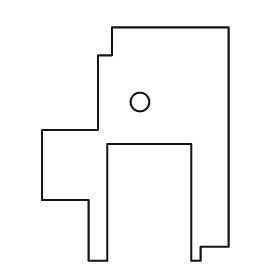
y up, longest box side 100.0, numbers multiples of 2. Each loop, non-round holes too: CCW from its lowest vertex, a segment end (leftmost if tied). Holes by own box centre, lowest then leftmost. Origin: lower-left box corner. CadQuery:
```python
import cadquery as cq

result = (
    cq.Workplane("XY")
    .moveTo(20.0, 0.0)
    .lineTo(28.0, 0.0)
    .lineTo(28.0, 50.0)
    .lineTo(64.0, 50.0)
    .lineTo(64.0, 0.0)
    .lineTo(68.0, 0.0)
    .lineTo(68.0, 6.0)
    .lineTo(80.0, 6.0)
    .lineTo(80.0, 100.0)
    .lineTo(30.0, 100.0)
    .lineTo(30.0, 88.0)
    .lineTo(24.0, 88.0)
    .lineTo(24.0, 56.0)
    .lineTo(0.0, 56.0)
    .lineTo(0.0, 26.0)
    .lineTo(20.0, 26.0)
    .close()
    .moveTo(42.0, 68.0)
    .circle(4.0)
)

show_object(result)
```